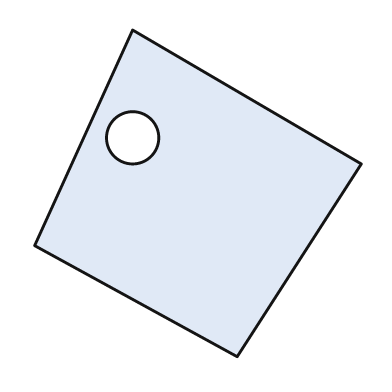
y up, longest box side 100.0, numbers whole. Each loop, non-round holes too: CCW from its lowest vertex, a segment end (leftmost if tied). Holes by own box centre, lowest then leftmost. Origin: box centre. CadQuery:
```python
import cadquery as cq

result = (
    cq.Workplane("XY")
    .moveTo(12.0, -50.0)
    .lineTo(50.0, 9.0)
    .lineTo(-20.0, 50.0)
    .lineTo(-50.0, -16.0)
    .close()
    .moveTo(-20.0, 17.0)
    .circle(8.0)
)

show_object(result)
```